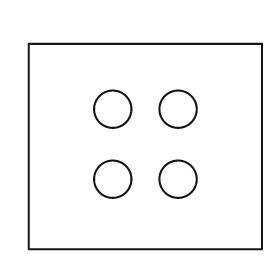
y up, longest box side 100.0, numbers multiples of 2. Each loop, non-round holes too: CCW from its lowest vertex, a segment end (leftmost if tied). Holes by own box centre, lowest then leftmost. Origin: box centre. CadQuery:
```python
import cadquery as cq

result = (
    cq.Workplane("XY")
    .moveTo(-50.0, -44.0)
    .lineTo(50.0, -44.0)
    .lineTo(50.0, 44.0)
    .lineTo(-50.0, 44.0)
    .close()
    .moveTo(-14.0, -14.0)
    .circle(8.0)
    .moveTo(14.0, -14.0)
    .circle(8.0)
    .moveTo(-14.0, 16.0)
    .circle(8.0)
    .moveTo(14.0, 16.0)
    .circle(8.0)
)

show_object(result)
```